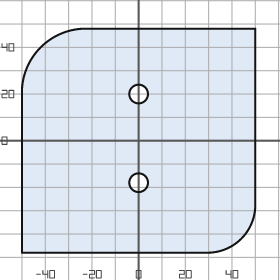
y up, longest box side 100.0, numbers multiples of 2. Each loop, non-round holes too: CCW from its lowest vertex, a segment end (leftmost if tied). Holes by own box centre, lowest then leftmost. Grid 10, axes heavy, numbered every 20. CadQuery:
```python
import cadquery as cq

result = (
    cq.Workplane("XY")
    .moveTo(-50.0, -48.0)
    .lineTo(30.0, -48.0)
    .threePointArc((44.0, -42.0), (50.0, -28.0))
    .lineTo(50.0, 48.0)
    .lineTo(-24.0, 48.0)
    .threePointArc((-42.0, 40.0), (-50.0, 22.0))
    .close()
    .moveTo(0.0, -18.0)
    .circle(4.0)
    .moveTo(0.0, 20.0)
    .circle(4.0)
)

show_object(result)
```